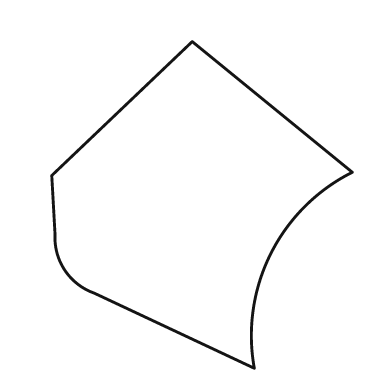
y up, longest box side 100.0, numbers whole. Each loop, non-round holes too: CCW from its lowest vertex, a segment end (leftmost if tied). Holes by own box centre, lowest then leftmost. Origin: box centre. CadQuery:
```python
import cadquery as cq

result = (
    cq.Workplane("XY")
    .moveTo(16.0, -50.0)
    .threePointArc((21.0, -15.0), (46.0, 10.0))
    .lineTo(-3.0, 50.0)
    .lineTo(-46.0, 9.0)
    .lineTo(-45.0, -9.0)
    .threePointArc((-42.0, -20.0), (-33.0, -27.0))
    .close()
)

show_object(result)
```